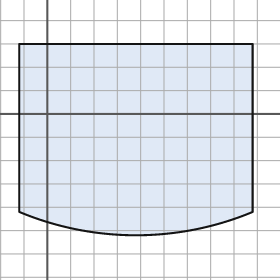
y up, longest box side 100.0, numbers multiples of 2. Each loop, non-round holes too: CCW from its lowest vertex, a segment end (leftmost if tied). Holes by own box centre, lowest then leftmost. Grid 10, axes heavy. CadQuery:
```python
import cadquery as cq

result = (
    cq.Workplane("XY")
    .moveTo(-12.0, -42.0)
    .threePointArc((38.0, -52.0), (88.0, -42.0))
    .lineTo(88.0, 30.0)
    .lineTo(-12.0, 30.0)
    .close()
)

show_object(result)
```